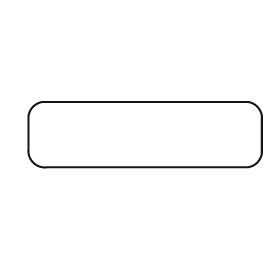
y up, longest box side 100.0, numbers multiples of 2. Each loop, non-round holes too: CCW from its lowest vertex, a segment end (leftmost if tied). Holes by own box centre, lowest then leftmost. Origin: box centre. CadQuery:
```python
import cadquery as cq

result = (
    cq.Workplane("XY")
    .moveTo(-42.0, -14.0)
    .lineTo(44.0, -14.0)
    .threePointArc((48.0, -12.0), (50.0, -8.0))
    .lineTo(50.0, 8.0)
    .threePointArc((48.0, 12.0), (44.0, 14.0))
    .lineTo(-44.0, 14.0)
    .threePointArc((-48.0, 12.0), (-50.0, 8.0))
    .lineTo(-50.0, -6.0)
    .threePointArc((-48.0, -12.0), (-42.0, -14.0))
    .close()
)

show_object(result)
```